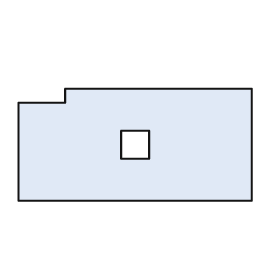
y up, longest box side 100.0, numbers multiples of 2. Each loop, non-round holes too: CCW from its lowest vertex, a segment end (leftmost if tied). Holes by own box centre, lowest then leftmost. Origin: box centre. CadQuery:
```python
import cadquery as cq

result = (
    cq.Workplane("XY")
    .moveTo(-50.0, -24.0)
    .lineTo(50.0, -24.0)
    .lineTo(50.0, 24.0)
    .lineTo(-30.0, 24.0)
    .lineTo(-30.0, 18.0)
    .lineTo(-50.0, 18.0)
    .close()
    .moveTo(-6.0, -6.0)
    .lineTo(6.0, -6.0)
    .lineTo(6.0, 6.0)
    .lineTo(-6.0, 6.0)
    .close()
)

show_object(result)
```